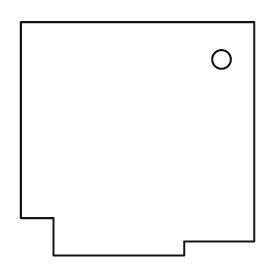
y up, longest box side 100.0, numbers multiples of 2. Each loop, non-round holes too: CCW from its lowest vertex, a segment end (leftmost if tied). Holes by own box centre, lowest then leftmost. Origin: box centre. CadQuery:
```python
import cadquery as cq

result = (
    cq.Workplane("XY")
    .moveTo(-36.0, -50.0)
    .lineTo(20.0, -50.0)
    .lineTo(20.0, -44.0)
    .lineTo(50.0, -44.0)
    .lineTo(50.0, 50.0)
    .lineTo(-50.0, 50.0)
    .lineTo(-50.0, -34.0)
    .lineTo(-36.0, -34.0)
    .close()
    .moveTo(36.0, 34.0)
    .circle(4.0)
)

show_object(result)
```